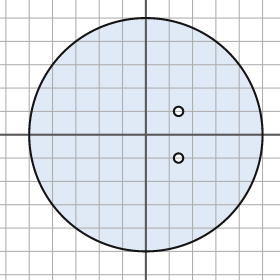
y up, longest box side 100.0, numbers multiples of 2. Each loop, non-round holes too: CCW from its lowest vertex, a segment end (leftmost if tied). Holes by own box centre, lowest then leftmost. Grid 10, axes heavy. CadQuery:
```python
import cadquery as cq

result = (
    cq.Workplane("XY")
    .moveTo(0.0, 0.0)
    .circle(50.0)
    .moveTo(14.0, -10.0)
    .circle(2.0)
    .moveTo(14.0, 10.0)
    .circle(2.0)
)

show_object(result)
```